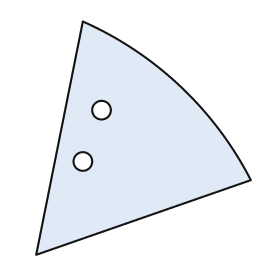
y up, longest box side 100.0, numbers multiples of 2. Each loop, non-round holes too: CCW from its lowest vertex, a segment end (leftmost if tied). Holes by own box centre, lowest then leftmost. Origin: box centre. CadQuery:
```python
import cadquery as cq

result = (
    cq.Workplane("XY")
    .moveTo(-46.0, -50.0)
    .lineTo(46.0, -18.0)
    .threePointArc((16.0, 22.0), (-26.0, 50.0))
    .close()
    .moveTo(-26.0, -10.0)
    .circle(4.0)
    .moveTo(-18.0, 12.0)
    .circle(4.0)
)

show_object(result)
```